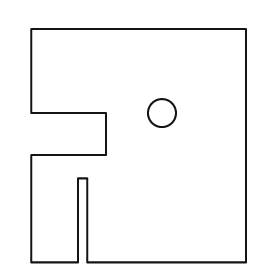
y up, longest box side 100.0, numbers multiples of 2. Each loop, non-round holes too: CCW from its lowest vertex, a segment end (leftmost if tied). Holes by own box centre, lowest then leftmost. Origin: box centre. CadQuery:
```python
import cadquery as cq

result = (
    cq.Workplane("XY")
    .moveTo(-46.0, -50.0)
    .lineTo(-26.0, -50.0)
    .lineTo(-26.0, -14.0)
    .lineTo(-22.0, -14.0)
    .lineTo(-22.0, -50.0)
    .lineTo(46.0, -50.0)
    .lineTo(46.0, 50.0)
    .lineTo(-46.0, 50.0)
    .lineTo(-46.0, 14.0)
    .lineTo(-14.0, 14.0)
    .lineTo(-14.0, -4.0)
    .lineTo(-46.0, -4.0)
    .close()
    .moveTo(10.0, 14.0)
    .circle(6.0)
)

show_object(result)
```